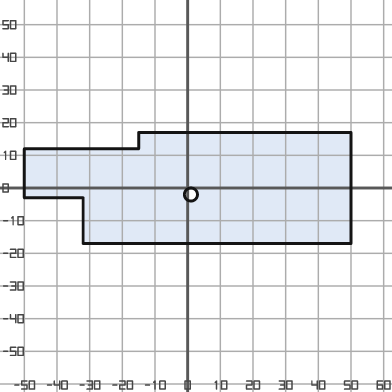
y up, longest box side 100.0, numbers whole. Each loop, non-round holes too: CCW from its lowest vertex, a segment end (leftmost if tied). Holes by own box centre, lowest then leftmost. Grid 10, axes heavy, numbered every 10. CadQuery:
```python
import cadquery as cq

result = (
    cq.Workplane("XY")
    .moveTo(-32.0, -17.0)
    .lineTo(50.0, -17.0)
    .lineTo(50.0, 17.0)
    .lineTo(-15.0, 17.0)
    .lineTo(-15.0, 12.0)
    .lineTo(-50.0, 12.0)
    .lineTo(-50.0, -3.0)
    .lineTo(-32.0, -3.0)
    .close()
    .moveTo(1.0, -2.0)
    .circle(2.0)
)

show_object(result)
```